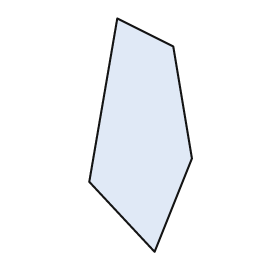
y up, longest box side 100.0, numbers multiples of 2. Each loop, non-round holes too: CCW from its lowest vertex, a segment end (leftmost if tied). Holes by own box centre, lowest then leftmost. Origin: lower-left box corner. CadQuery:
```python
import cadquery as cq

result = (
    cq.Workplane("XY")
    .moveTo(28.0, 0.0)
    .lineTo(44.0, 40.0)
    .lineTo(36.0, 88.0)
    .lineTo(12.0, 100.0)
    .lineTo(0.0, 30.0)
    .close()
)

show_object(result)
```